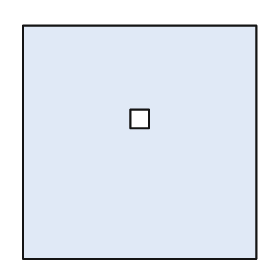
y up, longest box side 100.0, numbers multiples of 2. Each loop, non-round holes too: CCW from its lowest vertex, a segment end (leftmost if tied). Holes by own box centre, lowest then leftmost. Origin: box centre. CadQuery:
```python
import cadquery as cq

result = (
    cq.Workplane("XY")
    .moveTo(-50.0, -50.0)
    .lineTo(50.0, -50.0)
    .lineTo(50.0, 50.0)
    .lineTo(-50.0, 50.0)
    .close()
    .moveTo(-4.0, 6.0)
    .lineTo(4.0, 6.0)
    .lineTo(4.0, 14.0)
    .lineTo(-4.0, 14.0)
    .close()
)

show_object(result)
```